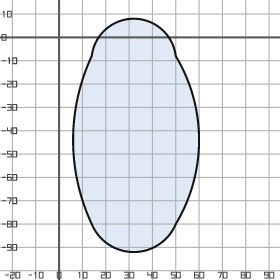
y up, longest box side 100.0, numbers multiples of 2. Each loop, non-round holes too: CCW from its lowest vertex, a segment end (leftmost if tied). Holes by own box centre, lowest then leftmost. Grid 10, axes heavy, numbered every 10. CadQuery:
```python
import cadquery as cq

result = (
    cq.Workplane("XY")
    .moveTo(14.0, -80.0)
    .threePointArc((32.0, -92.0), (50.0, -80.0))
    .threePointArc((60.0, -44.0), (50.0, -8.0))
    .threePointArc((32.0, 8.0), (14.0, -8.0))
    .threePointArc((6.0, -44.0), (14.0, -80.0))
    .close()
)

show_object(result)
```